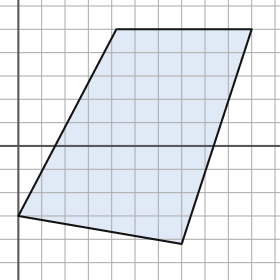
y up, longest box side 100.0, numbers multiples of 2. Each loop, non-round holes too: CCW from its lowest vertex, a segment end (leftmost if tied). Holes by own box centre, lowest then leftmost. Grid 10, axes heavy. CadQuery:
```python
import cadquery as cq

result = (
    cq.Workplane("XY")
    .moveTo(70.0, -42.0)
    .lineTo(100.0, 50.0)
    .lineTo(42.0, 50.0)
    .lineTo(0.0, -30.0)
    .close()
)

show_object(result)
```